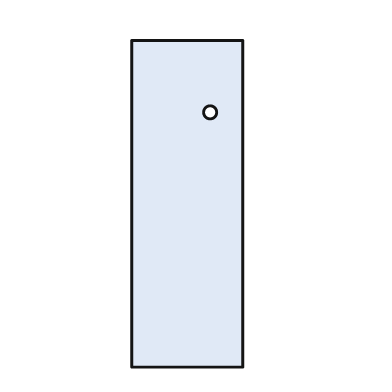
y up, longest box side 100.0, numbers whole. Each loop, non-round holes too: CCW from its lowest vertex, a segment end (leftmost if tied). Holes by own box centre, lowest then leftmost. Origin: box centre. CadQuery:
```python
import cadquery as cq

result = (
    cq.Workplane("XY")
    .moveTo(-17.0, -50.0)
    .lineTo(17.0, -50.0)
    .lineTo(17.0, 50.0)
    .lineTo(-17.0, 50.0)
    .close()
    .moveTo(7.0, 28.0)
    .circle(2.0)
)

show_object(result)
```